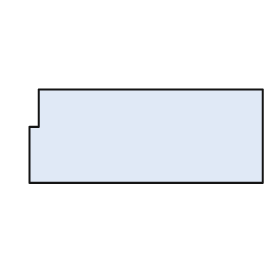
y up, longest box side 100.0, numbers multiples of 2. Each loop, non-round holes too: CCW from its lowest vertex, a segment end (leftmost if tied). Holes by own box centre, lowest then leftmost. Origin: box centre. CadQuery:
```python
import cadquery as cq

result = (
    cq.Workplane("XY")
    .moveTo(-50.0, -20.0)
    .lineTo(50.0, -20.0)
    .lineTo(50.0, 20.0)
    .lineTo(-46.0, 20.0)
    .lineTo(-46.0, 4.0)
    .lineTo(-50.0, 4.0)
    .close()
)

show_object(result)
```